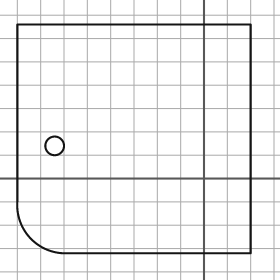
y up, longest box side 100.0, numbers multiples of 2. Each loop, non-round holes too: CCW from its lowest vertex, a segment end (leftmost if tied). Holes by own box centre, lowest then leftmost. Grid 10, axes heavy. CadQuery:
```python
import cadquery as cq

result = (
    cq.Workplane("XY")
    .moveTo(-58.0, -32.0)
    .lineTo(20.0, -32.0)
    .lineTo(20.0, 66.0)
    .lineTo(-80.0, 66.0)
    .lineTo(-80.0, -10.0)
    .threePointArc((-74.0, -26.0), (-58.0, -32.0))
    .close()
    .moveTo(-64.0, 14.0)
    .circle(4.0)
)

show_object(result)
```